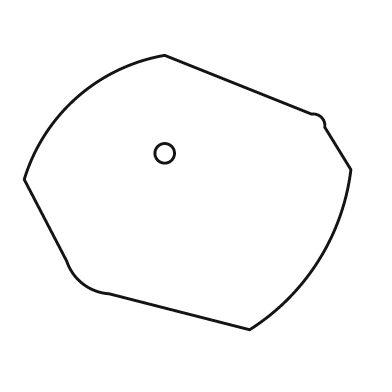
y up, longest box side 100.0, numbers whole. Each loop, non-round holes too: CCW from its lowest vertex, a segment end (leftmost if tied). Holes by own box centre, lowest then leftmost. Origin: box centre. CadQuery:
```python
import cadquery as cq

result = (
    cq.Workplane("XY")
    .moveTo(19.0, -42.0)
    .threePointArc((40.0, -21.0), (50.0, 7.0))
    .lineTo(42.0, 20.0)
    .threePointArc((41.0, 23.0), (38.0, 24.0))
    .lineTo(-7.0, 42.0)
    .threePointArc((-34.0, 29.0), (-50.0, 4.0))
    .lineTo(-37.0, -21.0)
    .threePointArc((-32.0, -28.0), (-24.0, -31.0))
    .close()
    .moveTo(-7.0, 12.0)
    .circle(3.0)
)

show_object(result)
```